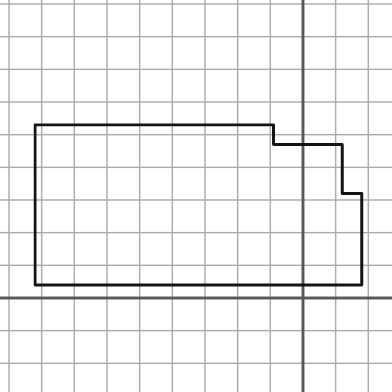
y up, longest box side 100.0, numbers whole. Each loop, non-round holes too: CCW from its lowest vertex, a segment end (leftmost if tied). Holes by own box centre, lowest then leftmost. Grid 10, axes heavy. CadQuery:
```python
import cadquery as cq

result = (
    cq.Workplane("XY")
    .moveTo(-82.0, 4.0)
    .lineTo(18.0, 4.0)
    .lineTo(18.0, 32.0)
    .lineTo(12.0, 32.0)
    .lineTo(12.0, 47.0)
    .lineTo(-9.0, 47.0)
    .lineTo(-9.0, 53.0)
    .lineTo(-82.0, 53.0)
    .close()
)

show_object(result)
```